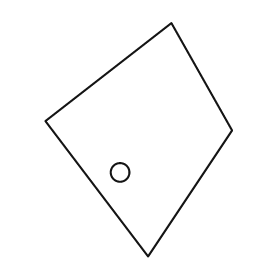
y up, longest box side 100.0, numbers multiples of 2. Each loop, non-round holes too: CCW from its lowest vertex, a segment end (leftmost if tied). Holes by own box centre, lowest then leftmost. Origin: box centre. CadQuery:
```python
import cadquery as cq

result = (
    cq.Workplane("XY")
    .moveTo(4.0, -50.0)
    .lineTo(40.0, 4.0)
    .lineTo(14.0, 50.0)
    .lineTo(-40.0, 8.0)
    .close()
    .moveTo(-8.0, -14.0)
    .circle(4.0)
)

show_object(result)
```